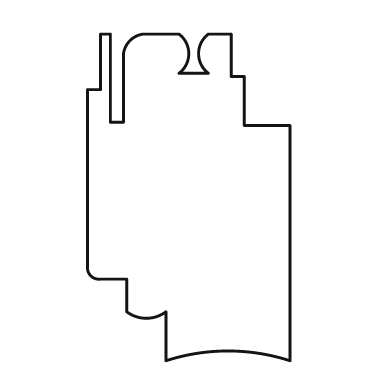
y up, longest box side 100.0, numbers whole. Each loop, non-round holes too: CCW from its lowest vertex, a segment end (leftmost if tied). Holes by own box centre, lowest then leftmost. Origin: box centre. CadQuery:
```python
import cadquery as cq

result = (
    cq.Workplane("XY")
    .moveTo(-7.0, -50.0)
    .threePointArc((12.0, -47.0), (31.0, -50.0))
    .lineTo(31.0, 22.0)
    .lineTo(17.0, 22.0)
    .lineTo(17.0, 37.0)
    .lineTo(13.0, 37.0)
    .lineTo(13.0, 50.0)
    .lineTo(6.0, 50.0)
    .threePointArc((3.0, 44.0), (6.0, 38.0))
    .lineTo(-3.0, 38.0)
    .threePointArc((0.0, 44.0), (-3.0, 50.0))
    .lineTo(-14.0, 50.0)
    .threePointArc((-18.0, 48.0), (-20.0, 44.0))
    .lineTo(-20.0, 23.0)
    .lineTo(-24.0, 23.0)
    .lineTo(-24.0, 50.0)
    .lineTo(-27.0, 50.0)
    .lineTo(-27.0, 33.0)
    .lineTo(-31.0, 33.0)
    .lineTo(-31.0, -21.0)
    .threePointArc((-30.0, -24.0), (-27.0, -25.0))
    .lineTo(-19.0, -25.0)
    .lineTo(-19.0, -35.0)
    .threePointArc((-13.0, -37.0), (-7.0, -35.0))
    .close()
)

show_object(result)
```